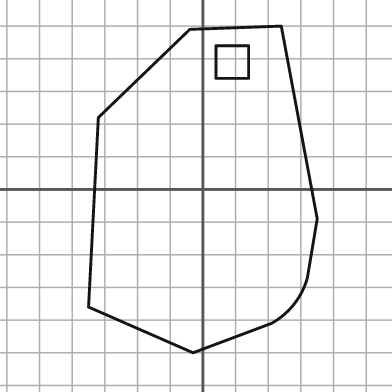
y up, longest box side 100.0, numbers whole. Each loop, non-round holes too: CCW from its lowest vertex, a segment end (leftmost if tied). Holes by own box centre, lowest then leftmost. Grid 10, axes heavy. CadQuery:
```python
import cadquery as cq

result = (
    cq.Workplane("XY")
    .moveTo(-3.0, -50.0)
    .lineTo(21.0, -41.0)
    .threePointArc((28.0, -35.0), (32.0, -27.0))
    .lineTo(35.0, -9.0)
    .lineTo(24.0, 50.0)
    .lineTo(-4.0, 49.0)
    .lineTo(-32.0, 22.0)
    .lineTo(-35.0, -36.0)
    .close()
    .moveTo(4.0, 34.0)
    .lineTo(14.0, 34.0)
    .lineTo(14.0, 44.0)
    .lineTo(4.0, 44.0)
    .close()
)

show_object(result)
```